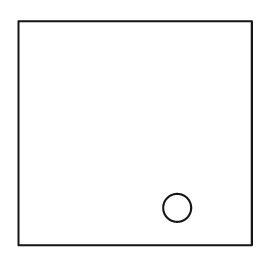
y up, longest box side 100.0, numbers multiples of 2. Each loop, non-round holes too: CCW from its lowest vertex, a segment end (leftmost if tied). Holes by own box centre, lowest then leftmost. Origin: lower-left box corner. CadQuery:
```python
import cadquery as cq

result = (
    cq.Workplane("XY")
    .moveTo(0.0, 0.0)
    .lineTo(100.0, 0.0)
    .lineTo(100.0, 96.0)
    .lineTo(0.0, 96.0)
    .close()
    .moveTo(68.0, 16.0)
    .circle(6.0)
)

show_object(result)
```